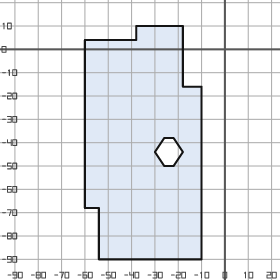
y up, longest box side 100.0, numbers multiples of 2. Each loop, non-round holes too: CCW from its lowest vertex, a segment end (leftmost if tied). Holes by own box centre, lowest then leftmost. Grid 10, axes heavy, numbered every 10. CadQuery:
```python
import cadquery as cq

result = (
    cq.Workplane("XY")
    .moveTo(-54.0, -90.0)
    .lineTo(-10.0, -90.0)
    .lineTo(-10.0, -16.0)
    .lineTo(-18.0, -16.0)
    .lineTo(-18.0, 10.0)
    .lineTo(-38.0, 10.0)
    .lineTo(-38.0, 4.0)
    .lineTo(-60.0, 4.0)
    .lineTo(-60.0, -68.0)
    .lineTo(-54.0, -68.0)
    .close()
    .moveTo(-26.0, -50.0)
    .lineTo(-22.0, -50.0)
    .lineTo(-18.0, -44.0)
    .lineTo(-22.0, -38.0)
    .lineTo(-26.0, -38.0)
    .lineTo(-30.0, -44.0)
    .close()
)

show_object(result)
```